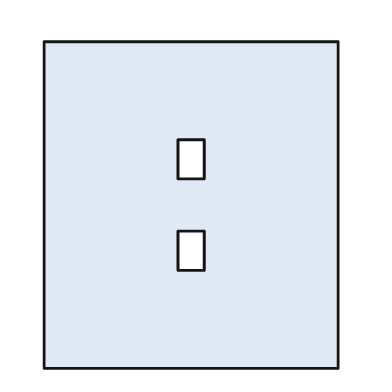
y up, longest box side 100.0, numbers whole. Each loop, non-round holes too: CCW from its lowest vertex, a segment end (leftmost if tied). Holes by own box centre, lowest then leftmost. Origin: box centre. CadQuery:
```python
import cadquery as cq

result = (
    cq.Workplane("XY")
    .moveTo(-45.0, -50.0)
    .lineTo(45.0, -50.0)
    .lineTo(45.0, 50.0)
    .lineTo(-45.0, 50.0)
    .close()
    .moveTo(-4.0, -20.0)
    .lineTo(4.0, -20.0)
    .lineTo(4.0, -8.0)
    .lineTo(-4.0, -8.0)
    .close()
    .moveTo(-4.0, 8.0)
    .lineTo(4.0, 8.0)
    .lineTo(4.0, 20.0)
    .lineTo(-4.0, 20.0)
    .close()
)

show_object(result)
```